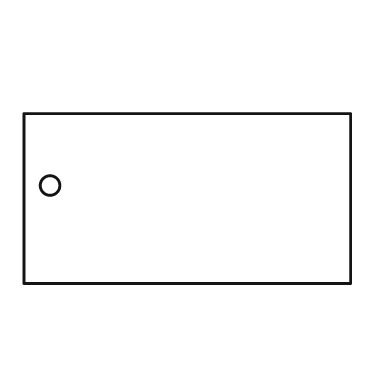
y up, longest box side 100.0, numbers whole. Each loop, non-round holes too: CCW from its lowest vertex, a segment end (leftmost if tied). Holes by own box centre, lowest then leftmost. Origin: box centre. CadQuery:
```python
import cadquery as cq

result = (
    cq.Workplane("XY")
    .moveTo(-50.0, -26.0)
    .lineTo(50.0, -26.0)
    .lineTo(50.0, 26.0)
    .lineTo(-50.0, 26.0)
    .close()
    .moveTo(-42.0, 4.0)
    .circle(3.0)
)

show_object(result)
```